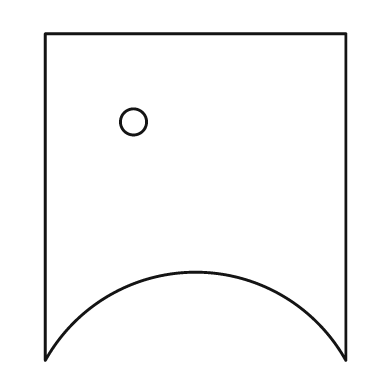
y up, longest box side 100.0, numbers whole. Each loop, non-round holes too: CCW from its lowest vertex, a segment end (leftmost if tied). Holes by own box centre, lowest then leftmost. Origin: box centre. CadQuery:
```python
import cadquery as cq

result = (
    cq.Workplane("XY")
    .moveTo(-46.0, -50.0)
    .threePointArc((0.0, -23.0), (46.0, -50.0))
    .lineTo(46.0, 50.0)
    .lineTo(-46.0, 50.0)
    .close()
    .moveTo(-19.0, 23.0)
    .circle(4.0)
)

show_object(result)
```